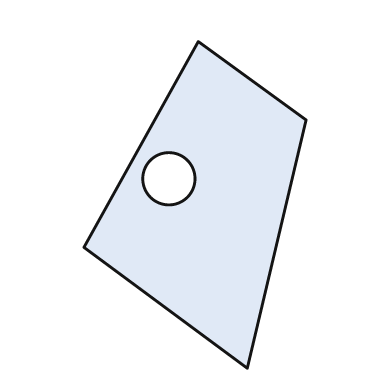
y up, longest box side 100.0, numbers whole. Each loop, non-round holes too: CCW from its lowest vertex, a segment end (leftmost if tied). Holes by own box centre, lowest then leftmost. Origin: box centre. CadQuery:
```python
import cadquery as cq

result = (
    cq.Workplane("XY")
    .moveTo(16.0, -50.0)
    .lineTo(34.0, 26.0)
    .lineTo(1.0, 50.0)
    .lineTo(-34.0, -13.0)
    .close()
    .moveTo(-8.0, 8.0)
    .circle(8.0)
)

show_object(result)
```